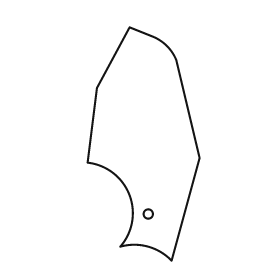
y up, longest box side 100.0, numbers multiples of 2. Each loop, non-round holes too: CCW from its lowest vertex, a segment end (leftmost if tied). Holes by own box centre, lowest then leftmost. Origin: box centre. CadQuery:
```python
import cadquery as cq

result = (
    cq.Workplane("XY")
    .moveTo(12.0, -50.0)
    .lineTo(24.0, -6.0)
    .lineTo(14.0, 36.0)
    .threePointArc((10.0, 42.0), (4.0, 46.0))
    .lineTo(-6.0, 50.0)
    .lineTo(-20.0, 24.0)
    .lineTo(-24.0, -8.0)
    .threePointArc((-6.0, -22.0), (-10.0, -44.0))
    .threePointArc((2.0, -44.0), (12.0, -50.0))
    .close()
    .moveTo(2.0, -30.0)
    .circle(2.0)
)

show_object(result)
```